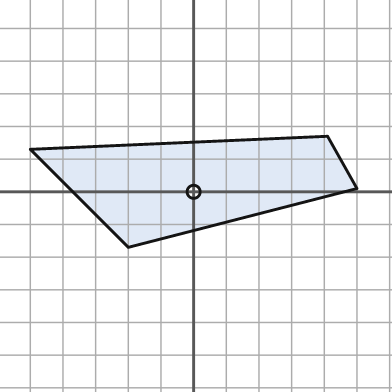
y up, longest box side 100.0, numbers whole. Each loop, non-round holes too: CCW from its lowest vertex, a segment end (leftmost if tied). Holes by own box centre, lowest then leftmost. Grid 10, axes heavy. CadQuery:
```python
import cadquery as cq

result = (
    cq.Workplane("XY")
    .moveTo(-20.0, -17.0)
    .lineTo(50.0, 1.0)
    .lineTo(41.0, 17.0)
    .lineTo(-50.0, 13.0)
    .close()
    .moveTo(0.0, 0.0)
    .circle(2.0)
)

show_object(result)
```